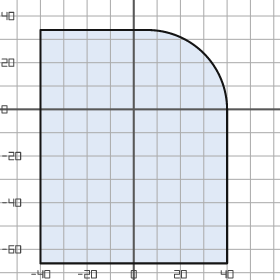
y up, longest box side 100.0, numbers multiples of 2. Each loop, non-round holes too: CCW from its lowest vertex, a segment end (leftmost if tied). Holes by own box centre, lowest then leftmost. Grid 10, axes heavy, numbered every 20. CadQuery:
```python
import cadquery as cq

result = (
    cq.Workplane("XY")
    .moveTo(-40.0, -66.0)
    .lineTo(40.0, -66.0)
    .lineTo(40.0, 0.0)
    .threePointArc((30.0, 24.0), (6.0, 34.0))
    .lineTo(-40.0, 34.0)
    .close()
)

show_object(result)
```